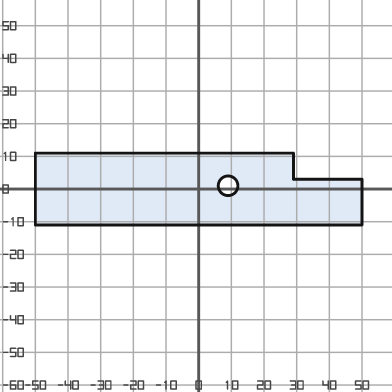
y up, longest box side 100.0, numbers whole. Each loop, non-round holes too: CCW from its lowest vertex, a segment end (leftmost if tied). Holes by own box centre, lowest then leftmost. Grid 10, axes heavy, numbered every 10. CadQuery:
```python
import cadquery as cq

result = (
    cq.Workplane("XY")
    .moveTo(-50.0, -11.0)
    .lineTo(50.0, -11.0)
    .lineTo(50.0, 3.0)
    .lineTo(29.0, 3.0)
    .lineTo(29.0, 11.0)
    .lineTo(-50.0, 11.0)
    .close()
    .moveTo(9.0, 1.0)
    .circle(3.0)
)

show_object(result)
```